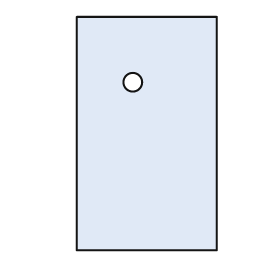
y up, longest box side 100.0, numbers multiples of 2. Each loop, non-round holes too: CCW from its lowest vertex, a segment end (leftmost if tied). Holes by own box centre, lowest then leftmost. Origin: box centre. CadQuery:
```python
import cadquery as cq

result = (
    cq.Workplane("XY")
    .moveTo(-30.0, -50.0)
    .lineTo(30.0, -50.0)
    .lineTo(30.0, 50.0)
    .lineTo(-30.0, 50.0)
    .close()
    .moveTo(-6.0, 22.0)
    .circle(4.0)
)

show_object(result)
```